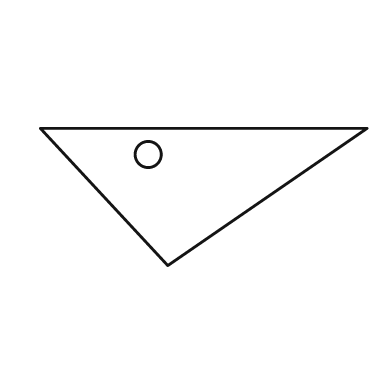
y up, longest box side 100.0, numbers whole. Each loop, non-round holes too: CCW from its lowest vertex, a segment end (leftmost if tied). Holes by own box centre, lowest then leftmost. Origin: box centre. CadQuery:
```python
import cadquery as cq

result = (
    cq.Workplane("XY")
    .moveTo(-11.0, -21.0)
    .lineTo(50.0, 21.0)
    .lineTo(-50.0, 21.0)
    .close()
    .moveTo(-17.0, 13.0)
    .circle(4.0)
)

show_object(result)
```